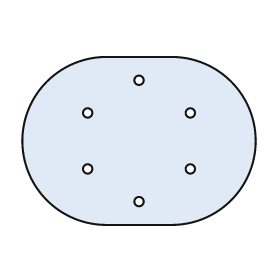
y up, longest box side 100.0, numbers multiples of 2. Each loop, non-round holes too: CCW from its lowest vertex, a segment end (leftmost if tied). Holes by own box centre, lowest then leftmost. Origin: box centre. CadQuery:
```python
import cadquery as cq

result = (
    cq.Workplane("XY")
    .moveTo(-14.0, -36.0)
    .lineTo(14.0, -36.0)
    .threePointArc((50.0, 0.0), (14.0, 36.0))
    .lineTo(-14.0, 36.0)
    .threePointArc((-50.0, 0.0), (-14.0, -36.0))
    .close()
    .moveTo(0.0, -26.0)
    .circle(2.0)
    .moveTo(-22.0, -12.0)
    .circle(2.0)
    .moveTo(22.0, -12.0)
    .circle(2.0)
    .moveTo(-22.0, 12.0)
    .circle(2.0)
    .moveTo(22.0, 12.0)
    .circle(2.0)
    .moveTo(0.0, 26.0)
    .circle(2.0)
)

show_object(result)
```